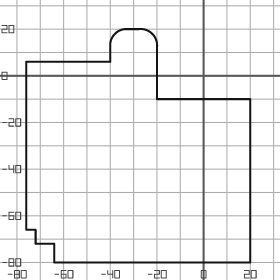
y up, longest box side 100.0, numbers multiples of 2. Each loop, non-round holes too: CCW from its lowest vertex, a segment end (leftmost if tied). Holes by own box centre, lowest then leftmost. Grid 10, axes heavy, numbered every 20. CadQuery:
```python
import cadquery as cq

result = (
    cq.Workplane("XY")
    .moveTo(-64.0, -80.0)
    .lineTo(20.0, -80.0)
    .lineTo(20.0, -10.0)
    .lineTo(-20.0, -10.0)
    .lineTo(-20.0, 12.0)
    .threePointArc((-22.0, 18.0), (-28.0, 20.0))
    .lineTo(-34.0, 20.0)
    .threePointArc((-38.0, 18.0), (-40.0, 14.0))
    .lineTo(-40.0, 6.0)
    .lineTo(-76.0, 6.0)
    .lineTo(-76.0, -66.0)
    .lineTo(-72.0, -66.0)
    .lineTo(-72.0, -72.0)
    .lineTo(-64.0, -72.0)
    .close()
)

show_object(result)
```